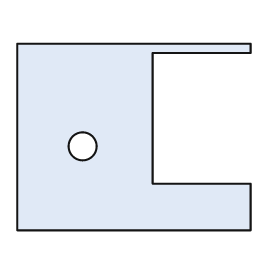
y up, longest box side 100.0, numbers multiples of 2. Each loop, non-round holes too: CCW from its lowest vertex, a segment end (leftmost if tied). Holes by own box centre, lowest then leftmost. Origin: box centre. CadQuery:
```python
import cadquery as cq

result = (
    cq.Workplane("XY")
    .moveTo(-50.0, -40.0)
    .lineTo(50.0, -40.0)
    .lineTo(50.0, -20.0)
    .lineTo(8.0, -20.0)
    .lineTo(8.0, 36.0)
    .lineTo(50.0, 36.0)
    .lineTo(50.0, 40.0)
    .lineTo(-50.0, 40.0)
    .close()
    .moveTo(-22.0, -4.0)
    .circle(6.0)
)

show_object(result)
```